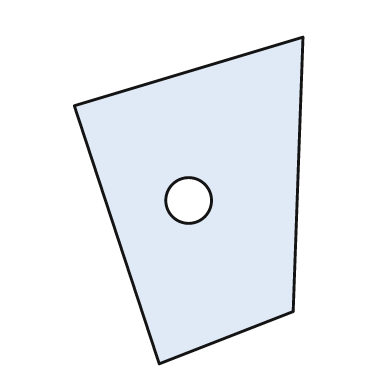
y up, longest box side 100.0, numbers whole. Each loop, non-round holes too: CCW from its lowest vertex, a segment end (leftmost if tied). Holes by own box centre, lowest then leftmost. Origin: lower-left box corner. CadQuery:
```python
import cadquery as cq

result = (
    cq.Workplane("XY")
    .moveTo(26.0, 0.0)
    .lineTo(67.0, 16.0)
    .lineTo(70.0, 100.0)
    .lineTo(0.0, 79.0)
    .close()
    .moveTo(35.0, 50.0)
    .circle(7.0)
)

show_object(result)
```